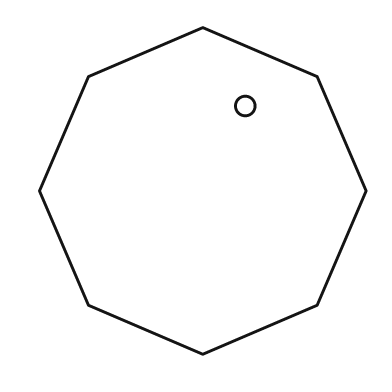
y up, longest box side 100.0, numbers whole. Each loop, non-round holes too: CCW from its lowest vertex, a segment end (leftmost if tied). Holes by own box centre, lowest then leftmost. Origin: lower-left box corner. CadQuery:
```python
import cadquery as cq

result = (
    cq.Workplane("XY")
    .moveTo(50.0, 0.0)
    .lineTo(85.0, 15.0)
    .lineTo(100.0, 50.0)
    .lineTo(85.0, 85.0)
    .lineTo(50.0, 100.0)
    .lineTo(15.0, 85.0)
    .lineTo(0.0, 50.0)
    .lineTo(15.0, 15.0)
    .close()
    .moveTo(63.0, 76.0)
    .circle(3.0)
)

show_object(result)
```